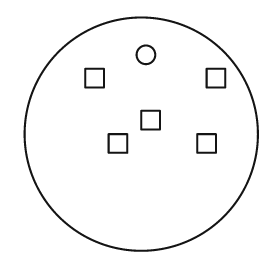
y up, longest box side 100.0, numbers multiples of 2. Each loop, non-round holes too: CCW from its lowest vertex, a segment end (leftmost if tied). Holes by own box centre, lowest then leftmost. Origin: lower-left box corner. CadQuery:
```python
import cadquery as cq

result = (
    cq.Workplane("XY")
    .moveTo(50.0, 50.0)
    .circle(50.0)
    .moveTo(36.0, 42.0)
    .lineTo(44.0, 42.0)
    .lineTo(44.0, 50.0)
    .lineTo(36.0, 50.0)
    .close()
    .moveTo(74.0, 42.0)
    .lineTo(82.0, 42.0)
    .lineTo(82.0, 50.0)
    .lineTo(74.0, 50.0)
    .close()
    .moveTo(50.0, 52.0)
    .lineTo(58.0, 52.0)
    .lineTo(58.0, 60.0)
    .lineTo(50.0, 60.0)
    .close()
    .moveTo(26.0, 70.0)
    .lineTo(34.0, 70.0)
    .lineTo(34.0, 78.0)
    .lineTo(26.0, 78.0)
    .close()
    .moveTo(78.0, 70.0)
    .lineTo(86.0, 70.0)
    .lineTo(86.0, 78.0)
    .lineTo(78.0, 78.0)
    .close()
    .moveTo(52.0, 84.0)
    .circle(4.0)
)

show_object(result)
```